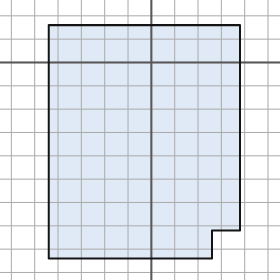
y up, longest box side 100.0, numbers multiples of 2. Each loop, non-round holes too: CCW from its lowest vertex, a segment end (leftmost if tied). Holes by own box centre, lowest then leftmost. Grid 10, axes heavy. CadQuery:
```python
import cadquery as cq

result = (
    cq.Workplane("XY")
    .moveTo(-44.0, -84.0)
    .lineTo(26.0, -84.0)
    .lineTo(26.0, -72.0)
    .lineTo(38.0, -72.0)
    .lineTo(38.0, 16.0)
    .lineTo(-44.0, 16.0)
    .close()
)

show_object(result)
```